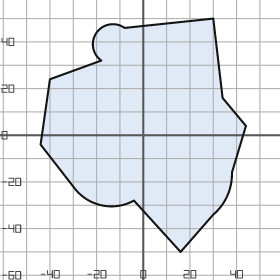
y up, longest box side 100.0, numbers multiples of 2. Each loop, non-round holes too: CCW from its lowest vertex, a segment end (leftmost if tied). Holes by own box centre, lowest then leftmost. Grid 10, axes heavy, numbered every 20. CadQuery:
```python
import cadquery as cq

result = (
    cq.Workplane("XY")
    .moveTo(16.0, -50.0)
    .lineTo(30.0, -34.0)
    .threePointArc((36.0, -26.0), (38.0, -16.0))
    .lineTo(44.0, 4.0)
    .lineTo(34.0, 16.0)
    .lineTo(30.0, 50.0)
    .lineTo(-8.0, 46.0)
    .threePointArc((-20.0, 44.0), (-18.0, 32.0))
    .lineTo(-40.0, 24.0)
    .lineTo(-44.0, -4.0)
    .lineTo(-30.0, -22.0)
    .threePointArc((-18.0, -30.0), (-4.0, -28.0))
    .close()
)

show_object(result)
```